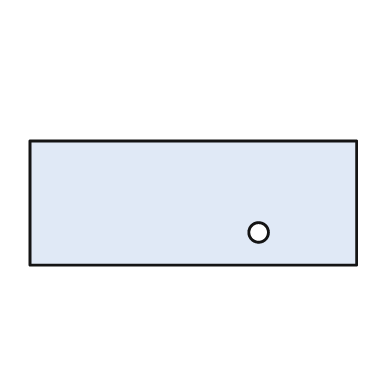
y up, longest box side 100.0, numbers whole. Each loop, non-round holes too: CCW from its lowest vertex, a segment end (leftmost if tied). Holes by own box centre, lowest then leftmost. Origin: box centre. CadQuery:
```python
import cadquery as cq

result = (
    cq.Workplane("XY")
    .moveTo(-50.0, -19.0)
    .lineTo(50.0, -19.0)
    .lineTo(50.0, 19.0)
    .lineTo(-50.0, 19.0)
    .close()
    .moveTo(20.0, -9.0)
    .circle(3.0)
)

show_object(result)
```